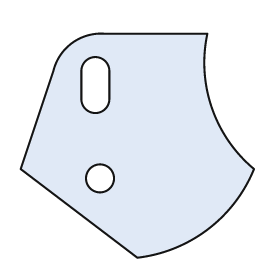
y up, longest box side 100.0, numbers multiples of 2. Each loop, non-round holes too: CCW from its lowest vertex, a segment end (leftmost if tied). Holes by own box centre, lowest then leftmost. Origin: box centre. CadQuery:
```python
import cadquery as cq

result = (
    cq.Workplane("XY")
    .moveTo(0.0, -48.0)
    .threePointArc((30.0, -36.0), (50.0, -10.0))
    .threePointArc((32.0, 16.0), (30.0, 48.0))
    .lineTo(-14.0, 48.0)
    .threePointArc((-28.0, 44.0), (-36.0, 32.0))
    .lineTo(-50.0, -10.0)
    .close()
    .moveTo(-16.0, -14.0)
    .circle(6.0)
    .moveTo(-24.0, 20.0)
    .threePointArc((-18.0, 14.0), (-12.0, 20.0))
    .lineTo(-12.0, 32.0)
    .threePointArc((-18.0, 38.0), (-24.0, 32.0))
    .close()
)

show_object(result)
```